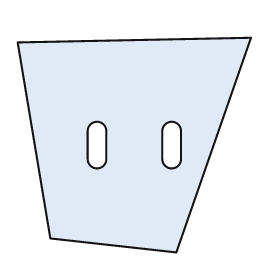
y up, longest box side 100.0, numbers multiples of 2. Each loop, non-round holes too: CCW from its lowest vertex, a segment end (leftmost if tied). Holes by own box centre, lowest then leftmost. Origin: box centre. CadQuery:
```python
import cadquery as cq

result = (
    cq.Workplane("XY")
    .moveTo(18.0, -46.0)
    .lineTo(50.0, 46.0)
    .lineTo(-50.0, 44.0)
    .lineTo(-36.0, -40.0)
    .close()
    .moveTo(-20.0, -6.0)
    .threePointArc((-16.0, -10.0), (-12.0, -6.0))
    .lineTo(-12.0, 6.0)
    .threePointArc((-16.0, 10.0), (-20.0, 6.0))
    .close()
    .moveTo(12.0, -6.0)
    .threePointArc((16.0, -10.0), (20.0, -6.0))
    .lineTo(20.0, 6.0)
    .threePointArc((16.0, 10.0), (12.0, 6.0))
    .close()
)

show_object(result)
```